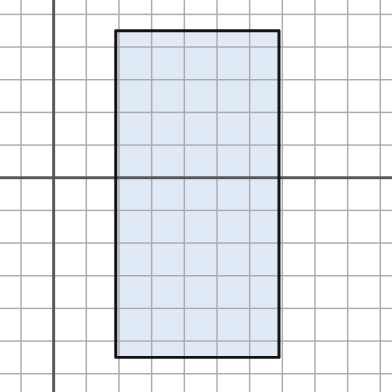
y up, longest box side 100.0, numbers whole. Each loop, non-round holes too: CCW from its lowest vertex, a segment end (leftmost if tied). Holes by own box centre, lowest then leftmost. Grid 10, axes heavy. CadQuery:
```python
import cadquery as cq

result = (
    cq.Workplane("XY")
    .moveTo(19.0, -55.0)
    .lineTo(69.0, -55.0)
    .lineTo(69.0, 45.0)
    .lineTo(19.0, 45.0)
    .close()
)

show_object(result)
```